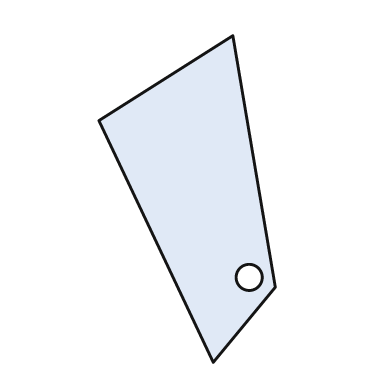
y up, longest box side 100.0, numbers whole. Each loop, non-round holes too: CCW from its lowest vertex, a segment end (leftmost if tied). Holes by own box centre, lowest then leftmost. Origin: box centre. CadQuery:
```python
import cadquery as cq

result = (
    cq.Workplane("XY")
    .moveTo(8.0, -50.0)
    .lineTo(27.0, -27.0)
    .lineTo(14.0, 50.0)
    .lineTo(-27.0, 24.0)
    .close()
    .moveTo(19.0, -24.0)
    .circle(4.0)
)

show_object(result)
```